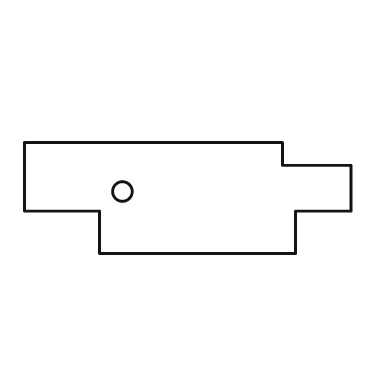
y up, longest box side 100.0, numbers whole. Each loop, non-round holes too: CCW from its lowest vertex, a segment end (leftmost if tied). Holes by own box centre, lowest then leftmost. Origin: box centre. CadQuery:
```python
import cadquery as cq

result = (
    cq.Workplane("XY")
    .moveTo(-27.0, -17.0)
    .lineTo(33.0, -17.0)
    .lineTo(33.0, -4.0)
    .lineTo(50.0, -4.0)
    .lineTo(50.0, 10.0)
    .lineTo(29.0, 10.0)
    .lineTo(29.0, 17.0)
    .lineTo(-50.0, 17.0)
    .lineTo(-50.0, -4.0)
    .lineTo(-27.0, -4.0)
    .close()
    .moveTo(-20.0, 2.0)
    .circle(3.0)
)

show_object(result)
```